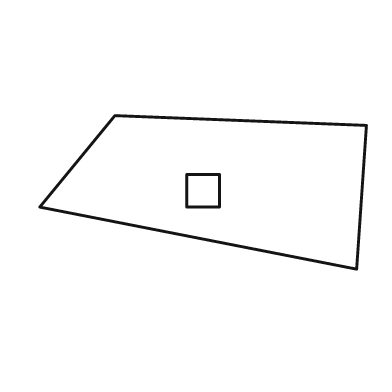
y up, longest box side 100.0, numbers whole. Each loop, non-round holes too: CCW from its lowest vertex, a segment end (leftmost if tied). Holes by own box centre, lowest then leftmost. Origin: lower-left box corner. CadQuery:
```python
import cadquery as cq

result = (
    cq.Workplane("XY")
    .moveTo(97.0, 0.0)
    .lineTo(100.0, 44.0)
    .lineTo(23.0, 47.0)
    .lineTo(0.0, 19.0)
    .close()
    .moveTo(45.0, 19.0)
    .lineTo(55.0, 19.0)
    .lineTo(55.0, 29.0)
    .lineTo(45.0, 29.0)
    .close()
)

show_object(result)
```